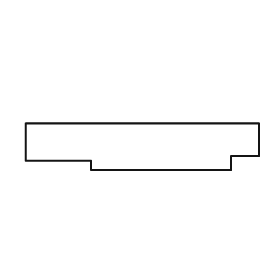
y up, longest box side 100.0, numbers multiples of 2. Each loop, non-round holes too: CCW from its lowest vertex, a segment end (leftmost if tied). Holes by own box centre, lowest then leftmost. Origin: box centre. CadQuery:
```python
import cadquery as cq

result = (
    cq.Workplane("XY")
    .moveTo(-22.0, -10.0)
    .lineTo(38.0, -10.0)
    .lineTo(38.0, -4.0)
    .lineTo(50.0, -4.0)
    .lineTo(50.0, 10.0)
    .lineTo(-50.0, 10.0)
    .lineTo(-50.0, -6.0)
    .lineTo(-22.0, -6.0)
    .close()
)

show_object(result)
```